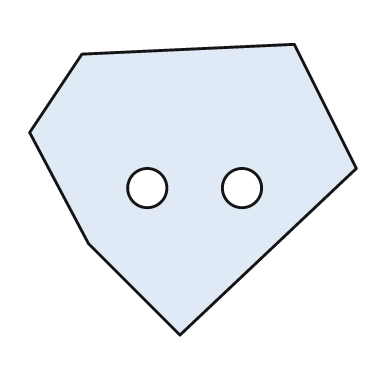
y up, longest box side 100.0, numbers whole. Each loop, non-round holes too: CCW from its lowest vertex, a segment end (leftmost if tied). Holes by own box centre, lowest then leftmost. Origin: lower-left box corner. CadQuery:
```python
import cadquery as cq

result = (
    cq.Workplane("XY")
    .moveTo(46.0, 0.0)
    .lineTo(100.0, 51.0)
    .lineTo(81.0, 89.0)
    .lineTo(16.0, 86.0)
    .lineTo(0.0, 62.0)
    .lineTo(18.0, 28.0)
    .close()
    .moveTo(36.0, 45.0)
    .circle(6.0)
    .moveTo(65.0, 45.0)
    .circle(6.0)
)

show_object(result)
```